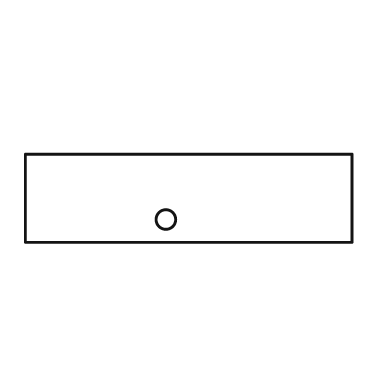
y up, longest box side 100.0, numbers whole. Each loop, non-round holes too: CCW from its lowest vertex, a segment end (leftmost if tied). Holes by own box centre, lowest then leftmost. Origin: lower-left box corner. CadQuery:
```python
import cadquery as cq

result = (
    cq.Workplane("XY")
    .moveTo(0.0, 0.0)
    .lineTo(100.0, 0.0)
    .lineTo(100.0, 27.0)
    .lineTo(0.0, 27.0)
    .close()
    .moveTo(43.0, 7.0)
    .circle(3.0)
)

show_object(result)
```